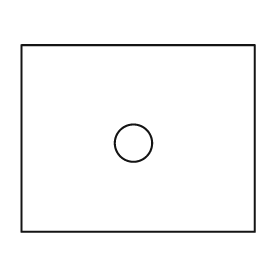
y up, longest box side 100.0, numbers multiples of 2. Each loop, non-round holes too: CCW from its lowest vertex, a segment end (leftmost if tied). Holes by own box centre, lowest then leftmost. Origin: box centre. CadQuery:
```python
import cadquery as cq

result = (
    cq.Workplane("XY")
    .moveTo(-50.0, -40.0)
    .lineTo(50.0, -40.0)
    .lineTo(50.0, 40.0)
    .lineTo(-50.0, 40.0)
    .close()
    .moveTo(-2.0, -2.0)
    .circle(8.0)
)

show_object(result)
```